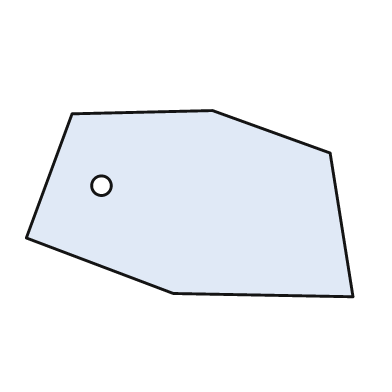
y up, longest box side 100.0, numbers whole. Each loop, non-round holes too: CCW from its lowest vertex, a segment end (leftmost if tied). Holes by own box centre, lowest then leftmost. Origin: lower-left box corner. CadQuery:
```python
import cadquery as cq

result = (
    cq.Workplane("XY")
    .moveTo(100.0, 0.0)
    .lineTo(93.0, 44.0)
    .lineTo(57.0, 57.0)
    .lineTo(14.0, 56.0)
    .lineTo(0.0, 18.0)
    .lineTo(45.0, 1.0)
    .close()
    .moveTo(23.0, 34.0)
    .circle(3.0)
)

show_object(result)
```